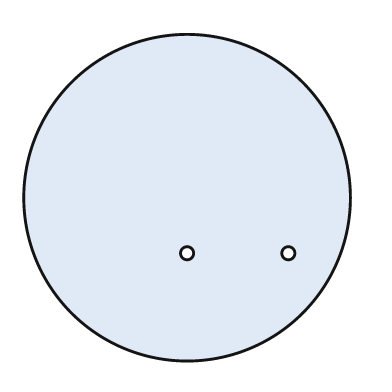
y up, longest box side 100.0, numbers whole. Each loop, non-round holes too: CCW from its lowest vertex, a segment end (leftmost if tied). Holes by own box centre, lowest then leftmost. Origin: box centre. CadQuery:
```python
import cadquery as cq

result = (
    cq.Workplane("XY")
    .moveTo(0.0, 0.0)
    .circle(50.0)
    .moveTo(0.0, -17.0)
    .circle(2.0)
    .moveTo(31.0, -17.0)
    .circle(2.0)
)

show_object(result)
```